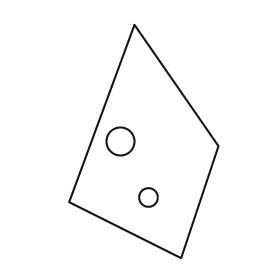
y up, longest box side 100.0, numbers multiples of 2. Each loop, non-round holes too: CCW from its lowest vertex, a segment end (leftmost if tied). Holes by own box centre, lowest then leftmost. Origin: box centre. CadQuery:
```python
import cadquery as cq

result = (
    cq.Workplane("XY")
    .moveTo(16.0, -50.0)
    .lineTo(32.0, -2.0)
    .lineTo(-4.0, 50.0)
    .lineTo(-32.0, -26.0)
    .close()
    .moveTo(2.0, -24.0)
    .circle(4.0)
    .moveTo(-10.0, 0.0)
    .circle(6.0)
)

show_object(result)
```